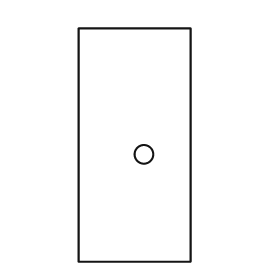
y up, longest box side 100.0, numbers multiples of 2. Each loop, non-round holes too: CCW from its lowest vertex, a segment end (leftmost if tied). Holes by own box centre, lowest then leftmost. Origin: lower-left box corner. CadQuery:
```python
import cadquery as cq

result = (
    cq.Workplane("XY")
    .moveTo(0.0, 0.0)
    .lineTo(48.0, 0.0)
    .lineTo(48.0, 100.0)
    .lineTo(0.0, 100.0)
    .close()
    .moveTo(28.0, 46.0)
    .circle(4.0)
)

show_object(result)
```